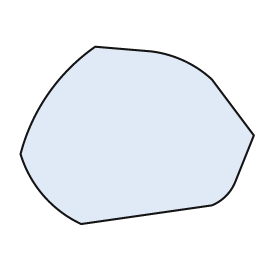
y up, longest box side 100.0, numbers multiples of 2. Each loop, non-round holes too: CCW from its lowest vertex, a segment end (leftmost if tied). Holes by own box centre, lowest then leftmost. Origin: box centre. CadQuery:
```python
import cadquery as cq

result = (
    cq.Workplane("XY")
    .moveTo(-24.0, -38.0)
    .lineTo(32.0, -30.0)
    .threePointArc((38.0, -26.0), (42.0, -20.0))
    .lineTo(50.0, 0.0)
    .lineTo(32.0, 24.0)
    .threePointArc((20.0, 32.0), (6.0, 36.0))
    .lineTo(-18.0, 38.0)
    .threePointArc((-38.0, 18.0), (-50.0, -8.0))
    .threePointArc((-40.0, -26.0), (-24.0, -38.0))
    .close()
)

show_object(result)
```